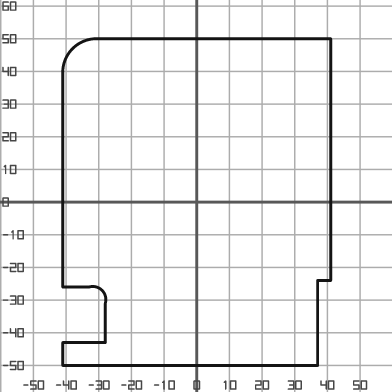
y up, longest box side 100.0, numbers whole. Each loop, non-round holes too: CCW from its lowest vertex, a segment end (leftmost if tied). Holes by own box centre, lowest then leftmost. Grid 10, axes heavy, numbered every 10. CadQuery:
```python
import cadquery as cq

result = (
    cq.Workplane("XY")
    .moveTo(-41.0, -50.0)
    .lineTo(37.0, -50.0)
    .lineTo(37.0, -24.0)
    .lineTo(41.0, -24.0)
    .lineTo(41.0, 50.0)
    .lineTo(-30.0, 50.0)
    .threePointArc((-38.0, 47.0), (-41.0, 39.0))
    .lineTo(-41.0, -26.0)
    .lineTo(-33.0, -26.0)
    .threePointArc((-29.0, -27.0), (-28.0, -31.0))
    .lineTo(-28.0, -43.0)
    .lineTo(-41.0, -43.0)
    .close()
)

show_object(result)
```